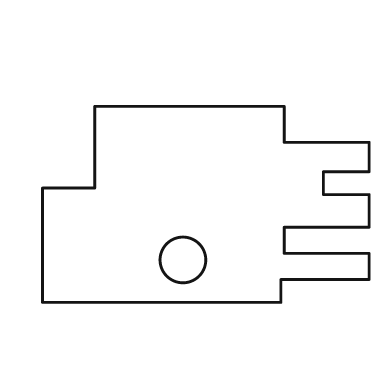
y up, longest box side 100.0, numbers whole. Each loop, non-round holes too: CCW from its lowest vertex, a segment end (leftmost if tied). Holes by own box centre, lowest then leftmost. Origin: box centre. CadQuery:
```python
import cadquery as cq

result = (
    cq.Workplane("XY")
    .moveTo(-50.0, -30.0)
    .lineTo(23.0, -30.0)
    .lineTo(23.0, -23.0)
    .lineTo(50.0, -23.0)
    .lineTo(50.0, -15.0)
    .lineTo(24.0, -15.0)
    .lineTo(24.0, -7.0)
    .lineTo(50.0, -7.0)
    .lineTo(50.0, 3.0)
    .lineTo(36.0, 3.0)
    .lineTo(36.0, 10.0)
    .lineTo(50.0, 10.0)
    .lineTo(50.0, 19.0)
    .lineTo(24.0, 19.0)
    .lineTo(24.0, 30.0)
    .lineTo(-34.0, 30.0)
    .lineTo(-34.0, 5.0)
    .lineTo(-50.0, 5.0)
    .close()
    .moveTo(-7.0, -17.0)
    .circle(7.0)
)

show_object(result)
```